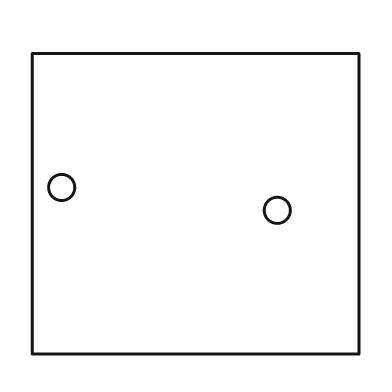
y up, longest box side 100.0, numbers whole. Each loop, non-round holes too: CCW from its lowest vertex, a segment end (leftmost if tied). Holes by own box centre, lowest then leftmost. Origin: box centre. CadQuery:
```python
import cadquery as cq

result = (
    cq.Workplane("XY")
    .moveTo(-50.0, -46.0)
    .lineTo(50.0, -46.0)
    .lineTo(50.0, 46.0)
    .lineTo(-50.0, 46.0)
    .close()
    .moveTo(25.0, -2.0)
    .circle(4.0)
    .moveTo(-41.0, 5.0)
    .circle(4.0)
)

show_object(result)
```